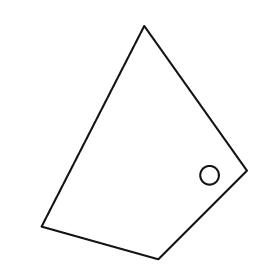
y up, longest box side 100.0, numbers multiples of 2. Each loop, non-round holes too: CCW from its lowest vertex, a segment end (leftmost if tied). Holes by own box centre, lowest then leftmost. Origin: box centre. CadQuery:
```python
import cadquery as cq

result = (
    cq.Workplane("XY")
    .moveTo(6.0, -50.0)
    .lineTo(44.0, -12.0)
    .lineTo(0.0, 50.0)
    .lineTo(-44.0, -36.0)
    .close()
    .moveTo(28.0, -14.0)
    .circle(4.0)
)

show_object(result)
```